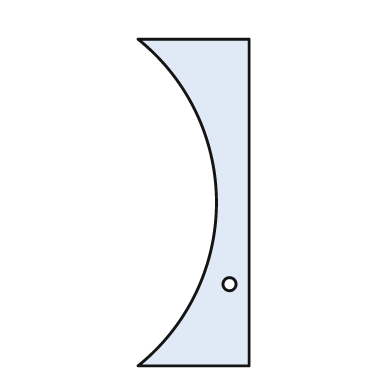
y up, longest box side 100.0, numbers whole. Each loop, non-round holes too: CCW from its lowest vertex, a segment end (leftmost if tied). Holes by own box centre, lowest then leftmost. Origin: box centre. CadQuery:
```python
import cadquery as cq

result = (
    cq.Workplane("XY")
    .moveTo(-17.0, -50.0)
    .lineTo(17.0, -50.0)
    .lineTo(17.0, 50.0)
    .lineTo(-17.0, 50.0)
    .threePointArc((7.0, 0.0), (-17.0, -50.0))
    .close()
    .moveTo(11.0, -25.0)
    .circle(2.0)
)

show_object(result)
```